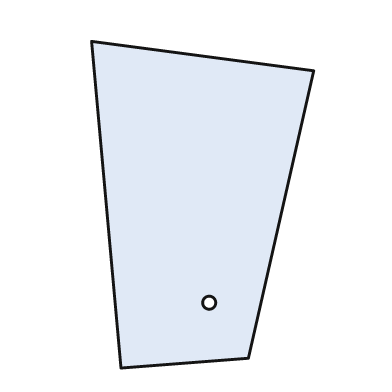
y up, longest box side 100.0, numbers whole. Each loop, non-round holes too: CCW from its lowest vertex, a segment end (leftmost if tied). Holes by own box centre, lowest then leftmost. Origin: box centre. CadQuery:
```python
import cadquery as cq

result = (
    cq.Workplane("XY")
    .moveTo(-25.0, -50.0)
    .lineTo(14.0, -47.0)
    .lineTo(34.0, 41.0)
    .lineTo(-34.0, 50.0)
    .close()
    .moveTo(2.0, -30.0)
    .circle(2.0)
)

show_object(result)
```